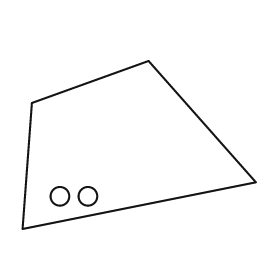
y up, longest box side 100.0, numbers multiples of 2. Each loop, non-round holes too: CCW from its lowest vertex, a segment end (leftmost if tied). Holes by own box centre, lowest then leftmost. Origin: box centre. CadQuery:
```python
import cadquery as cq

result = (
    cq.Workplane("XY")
    .moveTo(-50.0, -36.0)
    .lineTo(50.0, -16.0)
    .lineTo(4.0, 36.0)
    .lineTo(-46.0, 18.0)
    .close()
    .moveTo(-34.0, -22.0)
    .circle(4.0)
    .moveTo(-22.0, -22.0)
    .circle(4.0)
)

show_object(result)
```